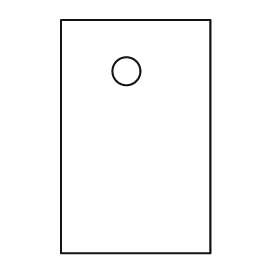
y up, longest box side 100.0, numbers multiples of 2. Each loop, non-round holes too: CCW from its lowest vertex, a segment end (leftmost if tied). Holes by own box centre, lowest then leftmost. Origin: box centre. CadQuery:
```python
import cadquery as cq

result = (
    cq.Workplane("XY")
    .moveTo(-32.0, -50.0)
    .lineTo(32.0, -50.0)
    .lineTo(32.0, 50.0)
    .lineTo(-32.0, 50.0)
    .close()
    .moveTo(-4.0, 28.0)
    .circle(6.0)
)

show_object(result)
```